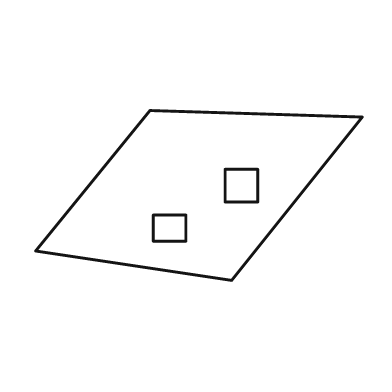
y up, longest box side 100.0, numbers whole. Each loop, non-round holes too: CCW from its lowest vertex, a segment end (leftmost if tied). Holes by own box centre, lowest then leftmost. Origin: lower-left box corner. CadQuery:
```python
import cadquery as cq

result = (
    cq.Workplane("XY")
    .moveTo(60.0, 0.0)
    .lineTo(100.0, 50.0)
    .lineTo(35.0, 52.0)
    .lineTo(0.0, 9.0)
    .close()
    .moveTo(36.0, 12.0)
    .lineTo(46.0, 12.0)
    .lineTo(46.0, 20.0)
    .lineTo(36.0, 20.0)
    .close()
    .moveTo(58.0, 24.0)
    .lineTo(68.0, 24.0)
    .lineTo(68.0, 34.0)
    .lineTo(58.0, 34.0)
    .close()
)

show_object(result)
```